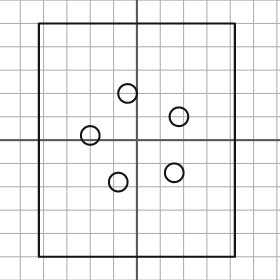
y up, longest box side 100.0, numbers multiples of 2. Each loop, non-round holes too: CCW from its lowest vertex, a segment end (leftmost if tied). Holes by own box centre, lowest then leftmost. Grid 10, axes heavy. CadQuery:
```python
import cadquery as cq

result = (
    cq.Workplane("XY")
    .moveTo(-42.0, -50.0)
    .lineTo(42.0, -50.0)
    .lineTo(42.0, 50.0)
    .lineTo(-42.0, 50.0)
    .close()
    .moveTo(-8.0, -18.0)
    .circle(4.0)
    .moveTo(16.0, -14.0)
    .circle(4.0)
    .moveTo(-20.0, 2.0)
    .circle(4.0)
    .moveTo(18.0, 10.0)
    .circle(4.0)
    .moveTo(-4.0, 20.0)
    .circle(4.0)
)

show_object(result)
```